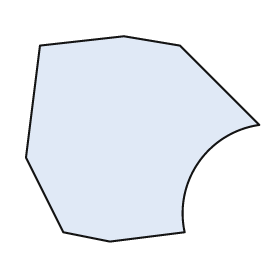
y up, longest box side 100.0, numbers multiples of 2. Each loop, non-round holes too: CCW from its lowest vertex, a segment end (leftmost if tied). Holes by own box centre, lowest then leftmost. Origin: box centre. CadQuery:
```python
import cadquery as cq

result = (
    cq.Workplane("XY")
    .moveTo(-14.0, -44.0)
    .lineTo(18.0, -40.0)
    .threePointArc((24.0, -10.0), (50.0, 6.0))
    .lineTo(16.0, 40.0)
    .lineTo(-8.0, 44.0)
    .lineTo(-44.0, 40.0)
    .lineTo(-50.0, -8.0)
    .lineTo(-34.0, -40.0)
    .close()
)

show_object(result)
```